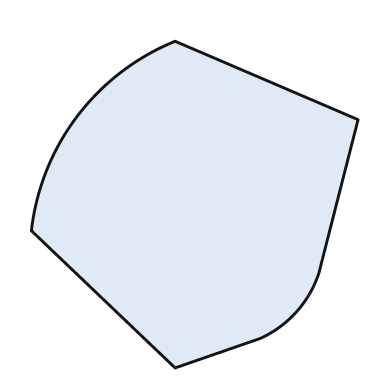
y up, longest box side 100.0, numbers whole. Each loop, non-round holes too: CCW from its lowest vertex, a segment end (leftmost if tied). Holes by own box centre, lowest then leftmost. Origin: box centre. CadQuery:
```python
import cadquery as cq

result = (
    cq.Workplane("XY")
    .moveTo(-6.0, -50.0)
    .lineTo(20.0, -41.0)
    .threePointArc((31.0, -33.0), (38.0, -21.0))
    .lineTo(50.0, 26.0)
    .lineTo(-6.0, 50.0)
    .threePointArc((-36.0, 27.0), (-50.0, -8.0))
    .close()
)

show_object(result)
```